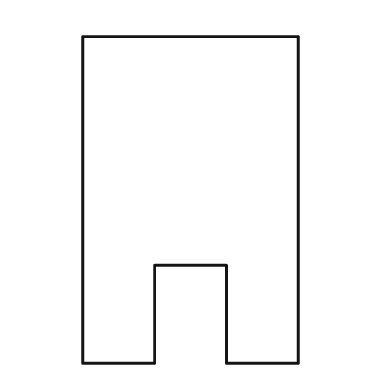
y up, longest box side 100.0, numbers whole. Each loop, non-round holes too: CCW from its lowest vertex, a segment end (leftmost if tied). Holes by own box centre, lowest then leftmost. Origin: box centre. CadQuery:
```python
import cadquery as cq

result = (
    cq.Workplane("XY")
    .moveTo(-33.0, -50.0)
    .lineTo(-11.0, -50.0)
    .lineTo(-11.0, -20.0)
    .lineTo(11.0, -20.0)
    .lineTo(11.0, -50.0)
    .lineTo(33.0, -50.0)
    .lineTo(33.0, 50.0)
    .lineTo(-33.0, 50.0)
    .close()
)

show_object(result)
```